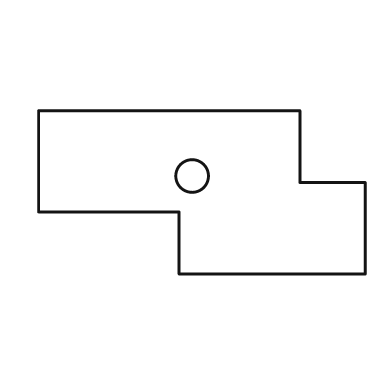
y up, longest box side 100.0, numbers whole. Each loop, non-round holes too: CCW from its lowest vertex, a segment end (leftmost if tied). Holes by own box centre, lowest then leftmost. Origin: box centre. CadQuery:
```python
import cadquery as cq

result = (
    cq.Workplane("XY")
    .moveTo(-7.0, -25.0)
    .lineTo(50.0, -25.0)
    .lineTo(50.0, 3.0)
    .lineTo(30.0, 3.0)
    .lineTo(30.0, 25.0)
    .lineTo(-50.0, 25.0)
    .lineTo(-50.0, -6.0)
    .lineTo(-7.0, -6.0)
    .close()
    .moveTo(-3.0, 5.0)
    .circle(5.0)
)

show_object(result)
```